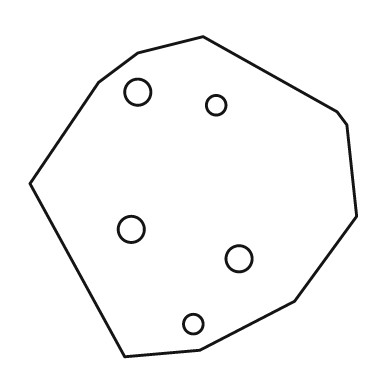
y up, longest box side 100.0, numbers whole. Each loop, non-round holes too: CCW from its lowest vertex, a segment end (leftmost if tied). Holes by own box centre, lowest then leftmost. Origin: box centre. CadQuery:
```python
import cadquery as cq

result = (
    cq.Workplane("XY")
    .moveTo(-21.0, -49.0)
    .lineTo(2.0, -47.0)
    .lineTo(31.0, -32.0)
    .lineTo(50.0, -6.0)
    .lineTo(47.0, 22.0)
    .lineTo(44.0, 26.0)
    .lineTo(3.0, 49.0)
    .lineTo(-17.0, 44.0)
    .lineTo(-29.0, 35.0)
    .lineTo(-50.0, 4.0)
    .close()
    .moveTo(0.0, -39.0)
    .circle(3.0)
    .moveTo(14.0, -19.0)
    .circle(4.0)
    .moveTo(-19.0, -10.0)
    .circle(4.0)
    .moveTo(7.0, 28.0)
    .circle(3.0)
    .moveTo(-17.0, 32.0)
    .circle(4.0)
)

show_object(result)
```